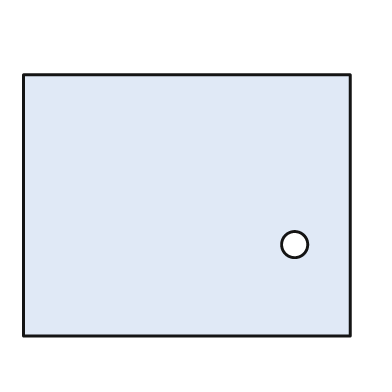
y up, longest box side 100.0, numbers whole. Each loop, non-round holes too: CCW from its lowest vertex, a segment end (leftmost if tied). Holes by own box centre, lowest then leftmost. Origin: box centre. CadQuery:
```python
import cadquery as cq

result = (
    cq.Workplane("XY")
    .moveTo(-50.0, -40.0)
    .lineTo(50.0, -40.0)
    .lineTo(50.0, 40.0)
    .lineTo(-50.0, 40.0)
    .close()
    .moveTo(33.0, -12.0)
    .circle(4.0)
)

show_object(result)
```